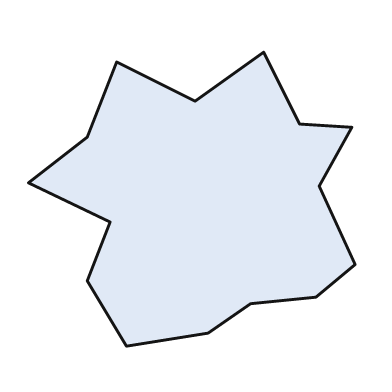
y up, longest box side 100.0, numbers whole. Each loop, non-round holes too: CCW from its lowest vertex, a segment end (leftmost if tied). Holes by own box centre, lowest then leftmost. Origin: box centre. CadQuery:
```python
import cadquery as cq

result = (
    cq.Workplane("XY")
    .moveTo(-20.0, -45.0)
    .lineTo(5.0, -41.0)
    .lineTo(18.0, -32.0)
    .lineTo(38.0, -30.0)
    .lineTo(50.0, -20.0)
    .lineTo(39.0, 4.0)
    .lineTo(49.0, 22.0)
    .lineTo(33.0, 23.0)
    .lineTo(22.0, 45.0)
    .lineTo(1.0, 30.0)
    .lineTo(-23.0, 42.0)
    .lineTo(-32.0, 19.0)
    .lineTo(-50.0, 5.0)
    .lineTo(-25.0, -7.0)
    .lineTo(-32.0, -25.0)
    .close()
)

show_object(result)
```